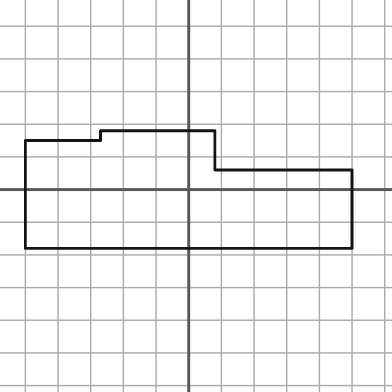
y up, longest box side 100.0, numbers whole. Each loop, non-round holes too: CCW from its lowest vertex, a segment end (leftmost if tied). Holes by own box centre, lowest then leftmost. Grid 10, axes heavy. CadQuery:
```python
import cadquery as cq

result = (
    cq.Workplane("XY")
    .moveTo(-50.0, -18.0)
    .lineTo(50.0, -18.0)
    .lineTo(50.0, 6.0)
    .lineTo(8.0, 6.0)
    .lineTo(8.0, 18.0)
    .lineTo(-27.0, 18.0)
    .lineTo(-27.0, 15.0)
    .lineTo(-50.0, 15.0)
    .close()
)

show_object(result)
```